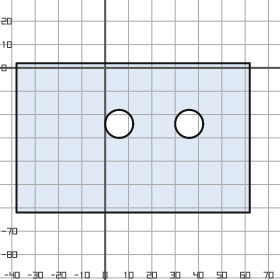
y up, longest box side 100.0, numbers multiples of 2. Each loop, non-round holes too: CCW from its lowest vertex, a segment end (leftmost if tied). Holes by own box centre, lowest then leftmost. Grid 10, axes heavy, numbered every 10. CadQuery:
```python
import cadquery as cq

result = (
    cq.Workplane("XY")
    .moveTo(-38.0, -62.0)
    .lineTo(62.0, -62.0)
    .lineTo(62.0, 2.0)
    .lineTo(-38.0, 2.0)
    .close()
    .moveTo(6.0, -24.0)
    .circle(6.0)
    .moveTo(36.0, -24.0)
    .circle(6.0)
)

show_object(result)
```